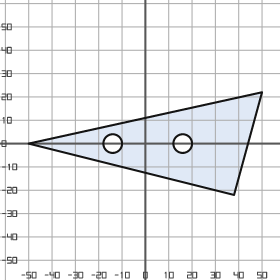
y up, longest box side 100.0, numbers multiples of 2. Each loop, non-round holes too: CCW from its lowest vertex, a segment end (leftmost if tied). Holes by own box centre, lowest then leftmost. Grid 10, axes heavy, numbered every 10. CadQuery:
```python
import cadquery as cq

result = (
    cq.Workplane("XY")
    .moveTo(38.0, -22.0)
    .lineTo(50.0, 22.0)
    .lineTo(-50.0, 0.0)
    .close()
    .moveTo(-14.0, 0.0)
    .circle(4.0)
    .moveTo(16.0, 0.0)
    .circle(4.0)
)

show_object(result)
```